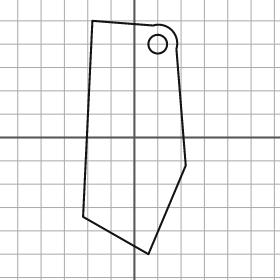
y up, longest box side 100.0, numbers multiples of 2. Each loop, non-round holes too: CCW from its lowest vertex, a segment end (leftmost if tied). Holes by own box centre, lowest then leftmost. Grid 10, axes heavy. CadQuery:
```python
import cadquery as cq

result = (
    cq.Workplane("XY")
    .moveTo(6.0, -50.0)
    .lineTo(22.0, -12.0)
    .lineTo(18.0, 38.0)
    .threePointArc((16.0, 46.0), (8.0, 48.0))
    .lineTo(-18.0, 50.0)
    .lineTo(-22.0, -34.0)
    .close()
    .moveTo(10.0, 40.0)
    .circle(4.0)
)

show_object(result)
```